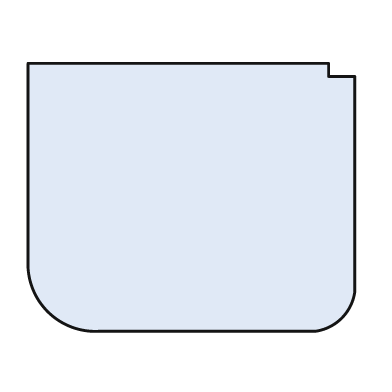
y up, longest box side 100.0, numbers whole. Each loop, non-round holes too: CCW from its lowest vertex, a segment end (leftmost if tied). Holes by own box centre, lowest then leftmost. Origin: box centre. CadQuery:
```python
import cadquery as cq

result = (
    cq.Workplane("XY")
    .moveTo(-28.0, -41.0)
    .lineTo(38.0, -41.0)
    .threePointArc((46.0, -37.0), (50.0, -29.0))
    .lineTo(50.0, 37.0)
    .lineTo(42.0, 37.0)
    .lineTo(42.0, 41.0)
    .lineTo(-50.0, 41.0)
    .lineTo(-50.0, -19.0)
    .threePointArc((-44.0, -35.0), (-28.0, -41.0))
    .close()
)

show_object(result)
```